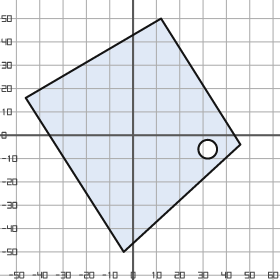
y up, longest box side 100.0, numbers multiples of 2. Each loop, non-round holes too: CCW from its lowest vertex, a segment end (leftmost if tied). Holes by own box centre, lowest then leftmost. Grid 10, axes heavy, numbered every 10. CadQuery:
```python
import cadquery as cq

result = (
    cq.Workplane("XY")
    .moveTo(-4.0, -50.0)
    .lineTo(46.0, -4.0)
    .lineTo(12.0, 50.0)
    .lineTo(-46.0, 16.0)
    .close()
    .moveTo(32.0, -6.0)
    .circle(4.0)
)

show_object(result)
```